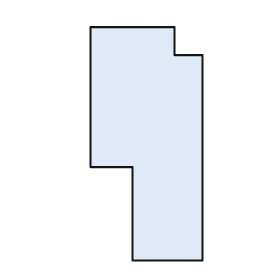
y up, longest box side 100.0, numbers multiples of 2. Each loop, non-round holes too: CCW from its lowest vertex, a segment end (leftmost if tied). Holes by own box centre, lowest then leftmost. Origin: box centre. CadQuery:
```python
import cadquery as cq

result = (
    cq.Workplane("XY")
    .moveTo(-6.0, -50.0)
    .lineTo(24.0, -50.0)
    .lineTo(24.0, 38.0)
    .lineTo(12.0, 38.0)
    .lineTo(12.0, 50.0)
    .lineTo(-24.0, 50.0)
    .lineTo(-24.0, -10.0)
    .lineTo(-6.0, -10.0)
    .close()
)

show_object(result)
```